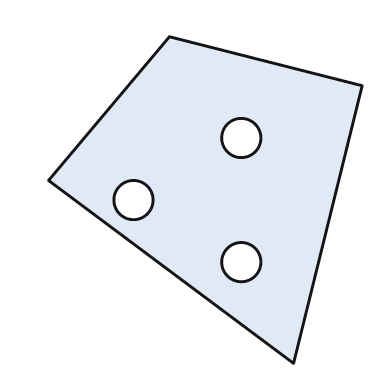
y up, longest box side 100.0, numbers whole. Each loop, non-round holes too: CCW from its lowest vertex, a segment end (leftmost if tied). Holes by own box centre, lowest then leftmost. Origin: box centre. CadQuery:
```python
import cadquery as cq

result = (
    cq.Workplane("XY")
    .moveTo(27.0, -50.0)
    .lineTo(48.0, 35.0)
    .lineTo(-11.0, 50.0)
    .lineTo(-48.0, 6.0)
    .close()
    .moveTo(11.0, -19.0)
    .circle(6.0)
    .moveTo(-22.0, 0.0)
    .circle(6.0)
    .moveTo(11.0, 19.0)
    .circle(6.0)
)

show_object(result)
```